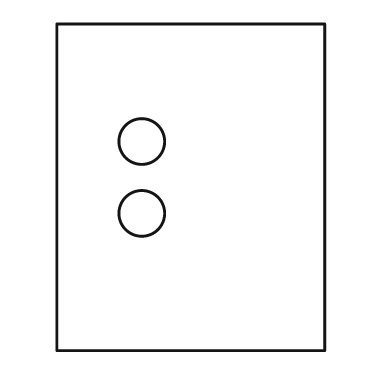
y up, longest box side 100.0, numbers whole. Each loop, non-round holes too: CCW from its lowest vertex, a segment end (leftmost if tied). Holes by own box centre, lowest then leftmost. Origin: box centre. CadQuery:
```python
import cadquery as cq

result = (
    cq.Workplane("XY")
    .moveTo(-41.0, -50.0)
    .lineTo(41.0, -50.0)
    .lineTo(41.0, 50.0)
    .lineTo(-41.0, 50.0)
    .close()
    .moveTo(-15.0, -8.0)
    .circle(7.0)
    .moveTo(-15.0, 14.0)
    .circle(7.0)
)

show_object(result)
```